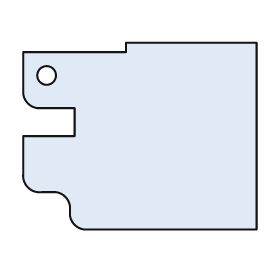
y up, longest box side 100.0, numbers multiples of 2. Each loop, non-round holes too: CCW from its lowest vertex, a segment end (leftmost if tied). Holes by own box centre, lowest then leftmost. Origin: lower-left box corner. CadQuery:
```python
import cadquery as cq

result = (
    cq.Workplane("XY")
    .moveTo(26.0, 0.0)
    .lineTo(100.0, 0.0)
    .lineTo(100.0, 80.0)
    .lineTo(44.0, 80.0)
    .lineTo(44.0, 76.0)
    .lineTo(0.0, 76.0)
    .lineTo(0.0, 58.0)
    .threePointArc((2.0, 54.0), (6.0, 52.0))
    .lineTo(22.0, 52.0)
    .lineTo(22.0, 40.0)
    .lineTo(0.0, 40.0)
    .lineTo(0.0, 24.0)
    .threePointArc((2.0, 18.0), (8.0, 16.0))
    .lineTo(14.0, 16.0)
    .threePointArc((18.0, 14.0), (20.0, 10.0))
    .lineTo(20.0, 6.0)
    .threePointArc((22.0, 2.0), (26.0, 0.0))
    .close()
    .moveTo(10.0, 66.0)
    .circle(4.0)
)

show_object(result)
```